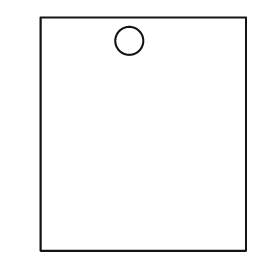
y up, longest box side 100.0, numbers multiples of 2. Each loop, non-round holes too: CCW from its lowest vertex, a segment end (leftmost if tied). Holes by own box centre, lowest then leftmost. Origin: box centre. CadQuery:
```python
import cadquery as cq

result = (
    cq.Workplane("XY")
    .moveTo(-44.0, -50.0)
    .lineTo(44.0, -50.0)
    .lineTo(44.0, 50.0)
    .lineTo(-44.0, 50.0)
    .close()
    .moveTo(-6.0, 40.0)
    .circle(6.0)
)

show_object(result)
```